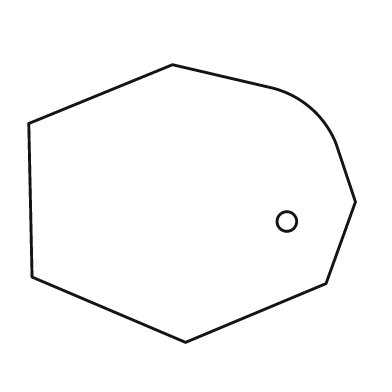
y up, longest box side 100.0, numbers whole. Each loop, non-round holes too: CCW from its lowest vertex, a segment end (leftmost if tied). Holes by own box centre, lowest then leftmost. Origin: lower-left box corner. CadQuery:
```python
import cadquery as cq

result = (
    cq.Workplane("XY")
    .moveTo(48.0, 0.0)
    .lineTo(91.0, 18.0)
    .lineTo(100.0, 43.0)
    .lineTo(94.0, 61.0)
    .threePointArc((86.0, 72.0), (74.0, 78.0))
    .lineTo(44.0, 85.0)
    .lineTo(0.0, 67.0)
    .lineTo(1.0, 20.0)
    .close()
    .moveTo(79.0, 37.0)
    .circle(3.0)
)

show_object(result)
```